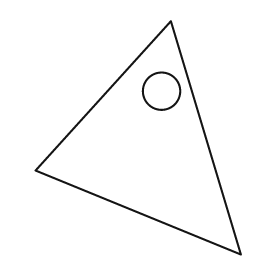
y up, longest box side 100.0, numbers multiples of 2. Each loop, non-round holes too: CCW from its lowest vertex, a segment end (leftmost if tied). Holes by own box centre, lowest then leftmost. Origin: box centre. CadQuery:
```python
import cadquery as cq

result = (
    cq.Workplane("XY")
    .moveTo(44.0, -50.0)
    .lineTo(14.0, 50.0)
    .lineTo(-44.0, -14.0)
    .close()
    .moveTo(10.0, 20.0)
    .circle(8.0)
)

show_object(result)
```